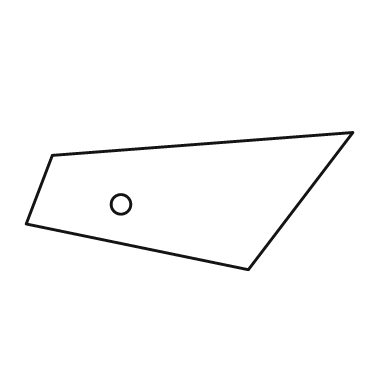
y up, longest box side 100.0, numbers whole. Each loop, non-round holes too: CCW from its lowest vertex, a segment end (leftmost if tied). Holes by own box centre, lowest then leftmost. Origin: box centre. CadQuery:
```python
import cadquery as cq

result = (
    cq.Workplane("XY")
    .moveTo(18.0, -21.0)
    .lineTo(50.0, 21.0)
    .lineTo(-42.0, 14.0)
    .lineTo(-50.0, -7.0)
    .close()
    .moveTo(-21.0, -1.0)
    .circle(3.0)
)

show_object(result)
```